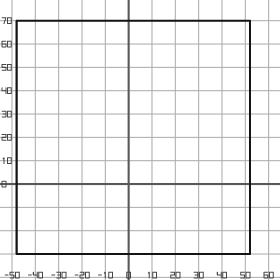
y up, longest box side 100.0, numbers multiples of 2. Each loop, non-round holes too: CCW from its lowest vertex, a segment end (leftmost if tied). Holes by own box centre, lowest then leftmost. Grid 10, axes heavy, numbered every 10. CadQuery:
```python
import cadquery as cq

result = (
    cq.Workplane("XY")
    .moveTo(-48.0, -30.0)
    .lineTo(52.0, -30.0)
    .lineTo(52.0, 70.0)
    .lineTo(-48.0, 70.0)
    .close()
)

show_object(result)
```